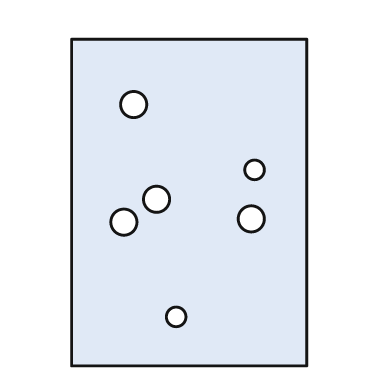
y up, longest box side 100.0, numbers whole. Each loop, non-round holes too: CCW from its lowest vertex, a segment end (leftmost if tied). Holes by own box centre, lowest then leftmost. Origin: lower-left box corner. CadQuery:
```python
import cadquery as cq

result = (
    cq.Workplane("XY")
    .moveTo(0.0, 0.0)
    .lineTo(72.0, 0.0)
    .lineTo(72.0, 100.0)
    .lineTo(0.0, 100.0)
    .close()
    .moveTo(32.0, 15.0)
    .circle(3.0)
    .moveTo(16.0, 44.0)
    .circle(4.0)
    .moveTo(55.0, 45.0)
    .circle(4.0)
    .moveTo(26.0, 51.0)
    .circle(4.0)
    .moveTo(56.0, 60.0)
    .circle(3.0)
    .moveTo(19.0, 80.0)
    .circle(4.0)
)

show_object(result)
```